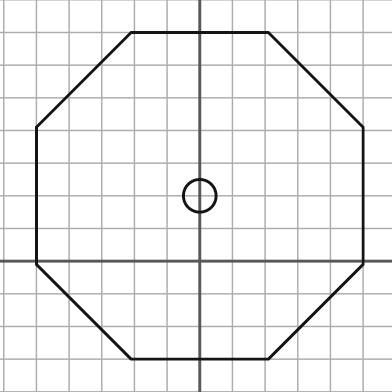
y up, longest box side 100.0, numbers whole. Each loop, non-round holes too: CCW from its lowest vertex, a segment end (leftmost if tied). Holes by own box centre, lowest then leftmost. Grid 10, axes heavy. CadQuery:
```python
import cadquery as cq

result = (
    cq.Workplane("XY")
    .moveTo(-21.0, -30.0)
    .lineTo(21.0, -30.0)
    .lineTo(50.0, -1.0)
    .lineTo(50.0, 41.0)
    .lineTo(21.0, 70.0)
    .lineTo(-21.0, 70.0)
    .lineTo(-50.0, 41.0)
    .lineTo(-50.0, -1.0)
    .close()
    .moveTo(0.0, 20.0)
    .circle(5.0)
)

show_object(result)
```